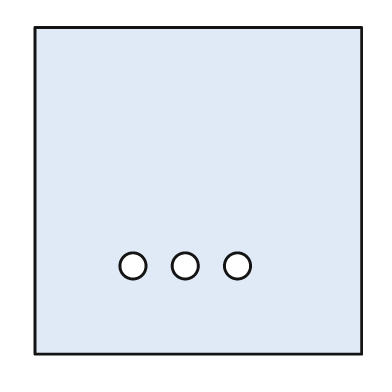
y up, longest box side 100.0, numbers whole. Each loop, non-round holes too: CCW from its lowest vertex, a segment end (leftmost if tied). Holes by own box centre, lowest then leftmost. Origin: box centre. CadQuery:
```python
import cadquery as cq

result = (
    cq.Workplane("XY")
    .moveTo(-50.0, -50.0)
    .lineTo(50.0, -50.0)
    .lineTo(50.0, 50.0)
    .lineTo(-50.0, 50.0)
    .close()
    .moveTo(-20.0, -23.0)
    .circle(4.0)
    .moveTo(-4.0, -23.0)
    .circle(4.0)
    .moveTo(12.0, -23.0)
    .circle(4.0)
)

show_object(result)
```